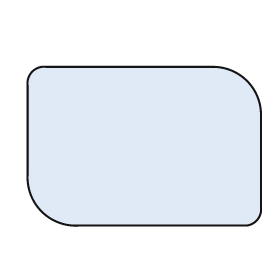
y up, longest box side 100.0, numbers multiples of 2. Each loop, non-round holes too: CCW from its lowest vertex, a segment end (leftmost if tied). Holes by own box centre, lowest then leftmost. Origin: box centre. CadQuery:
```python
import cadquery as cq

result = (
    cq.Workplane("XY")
    .moveTo(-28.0, -34.0)
    .lineTo(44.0, -34.0)
    .threePointArc((48.0, -32.0), (50.0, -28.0))
    .lineTo(50.0, 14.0)
    .threePointArc((44.0, 28.0), (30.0, 34.0))
    .lineTo(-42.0, 34.0)
    .threePointArc((-48.0, 32.0), (-50.0, 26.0))
    .lineTo(-50.0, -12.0)
    .threePointArc((-44.0, -28.0), (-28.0, -34.0))
    .close()
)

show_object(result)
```